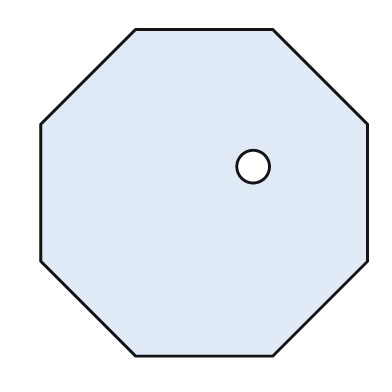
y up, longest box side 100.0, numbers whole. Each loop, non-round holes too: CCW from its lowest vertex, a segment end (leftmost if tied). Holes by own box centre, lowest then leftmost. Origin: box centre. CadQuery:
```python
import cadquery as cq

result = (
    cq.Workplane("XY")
    .moveTo(-21.0, -50.0)
    .lineTo(21.0, -50.0)
    .lineTo(50.0, -21.0)
    .lineTo(50.0, 21.0)
    .lineTo(21.0, 50.0)
    .lineTo(-21.0, 50.0)
    .lineTo(-50.0, 21.0)
    .lineTo(-50.0, -21.0)
    .close()
    .moveTo(15.0, 8.0)
    .circle(5.0)
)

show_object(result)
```